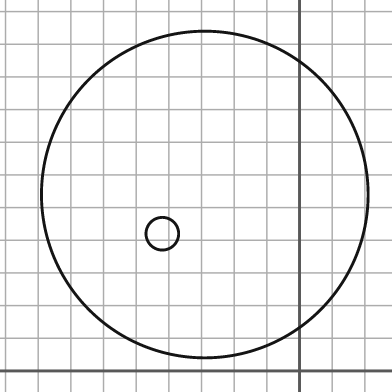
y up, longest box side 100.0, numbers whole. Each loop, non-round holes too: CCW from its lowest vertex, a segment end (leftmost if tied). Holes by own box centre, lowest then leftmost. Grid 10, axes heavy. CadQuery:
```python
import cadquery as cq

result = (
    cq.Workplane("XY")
    .moveTo(-29.0, 54.0)
    .circle(50.0)
    .moveTo(-42.0, 42.0)
    .circle(5.0)
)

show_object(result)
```